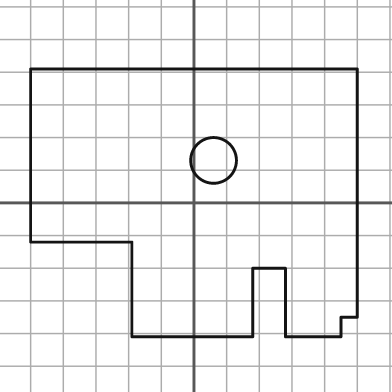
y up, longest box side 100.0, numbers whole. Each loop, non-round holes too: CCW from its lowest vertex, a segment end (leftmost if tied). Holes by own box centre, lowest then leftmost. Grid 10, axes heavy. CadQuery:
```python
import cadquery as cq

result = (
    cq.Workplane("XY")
    .moveTo(-19.0, -41.0)
    .lineTo(18.0, -41.0)
    .lineTo(18.0, -20.0)
    .lineTo(28.0, -20.0)
    .lineTo(28.0, -41.0)
    .lineTo(45.0, -41.0)
    .lineTo(45.0, -35.0)
    .lineTo(50.0, -35.0)
    .lineTo(50.0, 41.0)
    .lineTo(-50.0, 41.0)
    .lineTo(-50.0, -12.0)
    .lineTo(-19.0, -12.0)
    .close()
    .moveTo(6.0, 13.0)
    .circle(7.0)
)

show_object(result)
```